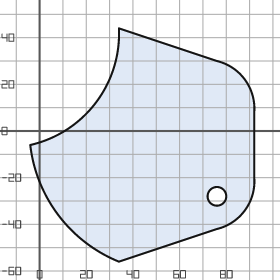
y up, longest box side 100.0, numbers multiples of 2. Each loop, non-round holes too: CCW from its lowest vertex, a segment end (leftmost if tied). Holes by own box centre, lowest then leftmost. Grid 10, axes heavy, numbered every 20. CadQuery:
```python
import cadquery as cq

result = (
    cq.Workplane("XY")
    .moveTo(34.0, -56.0)
    .lineTo(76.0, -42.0)
    .threePointArc((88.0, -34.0), (92.0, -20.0))
    .lineTo(92.0, 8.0)
    .threePointArc((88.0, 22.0), (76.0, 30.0))
    .lineTo(34.0, 44.0)
    .threePointArc((24.0, 12.0), (-4.0, -6.0))
    .threePointArc((8.0, -36.0), (34.0, -56.0))
    .close()
    .moveTo(76.0, -28.0)
    .circle(4.0)
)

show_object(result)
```